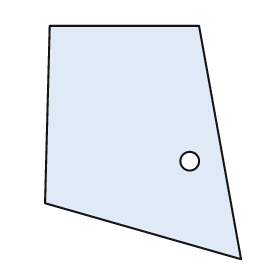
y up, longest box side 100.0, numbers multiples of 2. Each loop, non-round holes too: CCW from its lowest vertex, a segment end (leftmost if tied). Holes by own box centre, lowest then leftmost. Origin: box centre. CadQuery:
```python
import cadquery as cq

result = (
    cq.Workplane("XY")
    .moveTo(42.0, -50.0)
    .lineTo(24.0, 50.0)
    .lineTo(-40.0, 50.0)
    .lineTo(-42.0, -26.0)
    .close()
    .moveTo(20.0, -8.0)
    .circle(4.0)
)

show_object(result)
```